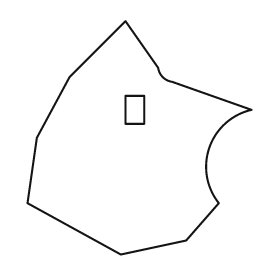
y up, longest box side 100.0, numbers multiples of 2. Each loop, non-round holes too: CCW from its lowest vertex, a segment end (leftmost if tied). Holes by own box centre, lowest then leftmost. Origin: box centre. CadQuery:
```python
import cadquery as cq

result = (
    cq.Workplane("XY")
    .moveTo(-8.0, -50.0)
    .lineTo(20.0, -44.0)
    .lineTo(34.0, -28.0)
    .threePointArc((30.0, -4.0), (48.0, 12.0))
    .lineTo(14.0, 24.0)
    .threePointArc((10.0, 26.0), (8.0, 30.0))
    .lineTo(-6.0, 50.0)
    .lineTo(-30.0, 26.0)
    .lineTo(-44.0, 0.0)
    .lineTo(-48.0, -28.0)
    .close()
    .moveTo(-6.0, 6.0)
    .lineTo(2.0, 6.0)
    .lineTo(2.0, 18.0)
    .lineTo(-6.0, 18.0)
    .close()
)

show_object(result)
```